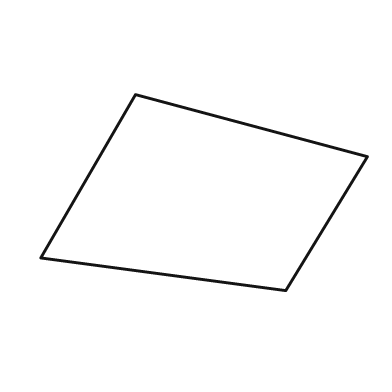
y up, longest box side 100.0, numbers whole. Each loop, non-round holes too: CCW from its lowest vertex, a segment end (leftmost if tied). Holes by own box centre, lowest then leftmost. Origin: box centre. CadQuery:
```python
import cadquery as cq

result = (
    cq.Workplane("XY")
    .moveTo(25.0, -30.0)
    .lineTo(50.0, 11.0)
    .lineTo(-21.0, 30.0)
    .lineTo(-50.0, -20.0)
    .close()
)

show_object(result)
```